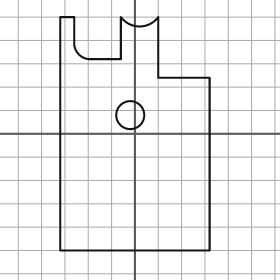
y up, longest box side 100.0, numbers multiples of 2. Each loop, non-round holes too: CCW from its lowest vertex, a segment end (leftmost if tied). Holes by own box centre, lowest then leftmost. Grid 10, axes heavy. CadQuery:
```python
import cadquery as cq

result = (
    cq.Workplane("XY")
    .moveTo(-32.0, -50.0)
    .lineTo(32.0, -50.0)
    .lineTo(32.0, 24.0)
    .lineTo(10.0, 24.0)
    .lineTo(10.0, 50.0)
    .threePointArc((2.0, 46.0), (-6.0, 50.0))
    .lineTo(-6.0, 32.0)
    .lineTo(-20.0, 32.0)
    .threePointArc((-24.0, 34.0), (-26.0, 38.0))
    .lineTo(-26.0, 50.0)
    .lineTo(-32.0, 50.0)
    .close()
    .moveTo(-2.0, 8.0)
    .circle(6.0)
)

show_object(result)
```